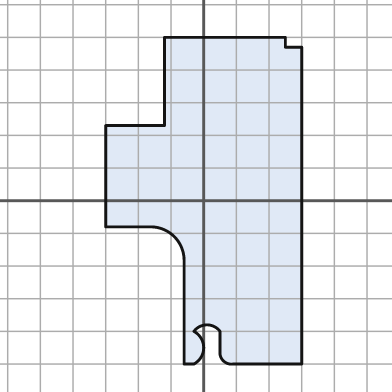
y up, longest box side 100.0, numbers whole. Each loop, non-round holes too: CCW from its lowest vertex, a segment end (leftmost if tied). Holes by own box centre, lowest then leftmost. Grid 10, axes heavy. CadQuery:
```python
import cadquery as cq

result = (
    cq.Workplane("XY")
    .moveTo(-6.0, -50.0)
    .lineTo(-3.0, -50.0)
    .threePointArc((0.0, -45.0), (-3.0, -40.0))
    .threePointArc((1.0, -38.0), (5.0, -40.0))
    .lineTo(5.0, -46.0)
    .threePointArc((6.0, -49.0), (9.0, -50.0))
    .lineTo(30.0, -50.0)
    .lineTo(30.0, 47.0)
    .lineTo(25.0, 47.0)
    .lineTo(25.0, 50.0)
    .lineTo(-12.0, 50.0)
    .lineTo(-12.0, 23.0)
    .lineTo(-30.0, 23.0)
    .lineTo(-30.0, -8.0)
    .lineTo(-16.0, -8.0)
    .threePointArc((-9.0, -11.0), (-6.0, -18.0))
    .close()
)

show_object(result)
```